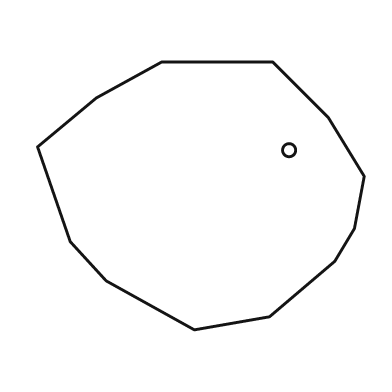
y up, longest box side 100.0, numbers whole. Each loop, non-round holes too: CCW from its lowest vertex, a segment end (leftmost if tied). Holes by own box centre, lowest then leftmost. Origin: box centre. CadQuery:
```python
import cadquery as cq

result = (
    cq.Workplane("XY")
    .moveTo(-2.0, -41.0)
    .lineTo(21.0, -37.0)
    .lineTo(41.0, -20.0)
    .lineTo(47.0, -10.0)
    .lineTo(50.0, 6.0)
    .lineTo(39.0, 24.0)
    .lineTo(22.0, 41.0)
    .lineTo(-12.0, 41.0)
    .lineTo(-32.0, 30.0)
    .lineTo(-50.0, 15.0)
    .lineTo(-40.0, -14.0)
    .lineTo(-29.0, -26.0)
    .close()
    .moveTo(27.0, 14.0)
    .circle(2.0)
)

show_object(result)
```